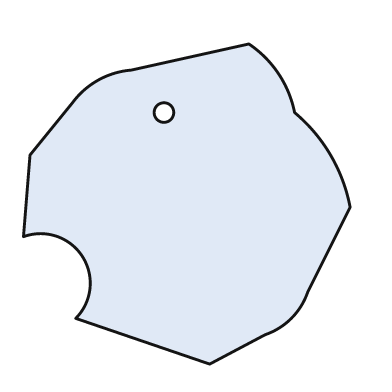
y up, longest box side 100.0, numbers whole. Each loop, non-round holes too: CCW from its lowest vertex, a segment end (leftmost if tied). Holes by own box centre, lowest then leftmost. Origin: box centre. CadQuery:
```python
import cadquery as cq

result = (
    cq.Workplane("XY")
    .moveTo(7.0, -49.0)
    .lineTo(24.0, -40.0)
    .threePointArc((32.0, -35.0), (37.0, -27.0))
    .lineTo(50.0, -1.0)
    .threePointArc((44.0, 15.0), (33.0, 28.0))
    .threePointArc((28.0, 40.0), (19.0, 49.0))
    .lineTo(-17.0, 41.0)
    .threePointArc((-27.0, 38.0), (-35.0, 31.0))
    .lineTo(-48.0, 15.0)
    .lineTo(-50.0, -10.0)
    .threePointArc((-32.0, -16.0), (-34.0, -35.0))
    .close()
    .moveTo(-7.0, 28.0)
    .circle(3.0)
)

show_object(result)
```